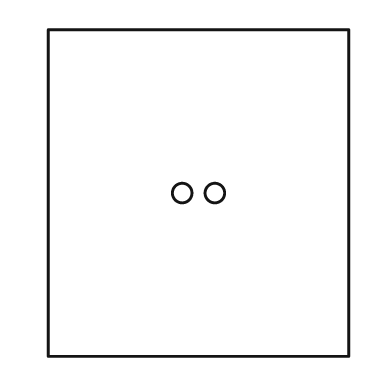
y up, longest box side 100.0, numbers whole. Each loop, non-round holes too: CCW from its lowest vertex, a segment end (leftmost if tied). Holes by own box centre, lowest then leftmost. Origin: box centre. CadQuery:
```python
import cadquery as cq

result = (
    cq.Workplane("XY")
    .moveTo(-46.0, -50.0)
    .lineTo(46.0, -50.0)
    .lineTo(46.0, 50.0)
    .lineTo(-46.0, 50.0)
    .close()
    .moveTo(-5.0, 0.0)
    .circle(3.0)
    .moveTo(5.0, 0.0)
    .circle(3.0)
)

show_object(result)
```